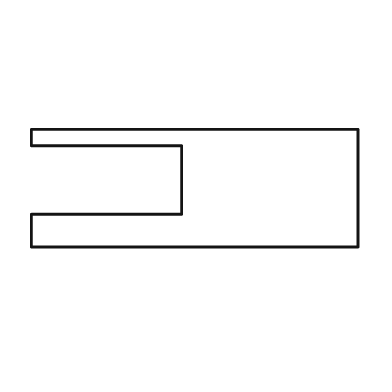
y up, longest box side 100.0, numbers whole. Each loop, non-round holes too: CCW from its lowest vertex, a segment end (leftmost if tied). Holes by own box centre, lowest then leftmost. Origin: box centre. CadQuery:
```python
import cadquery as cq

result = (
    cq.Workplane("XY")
    .moveTo(-50.0, -18.0)
    .lineTo(50.0, -18.0)
    .lineTo(50.0, 18.0)
    .lineTo(-50.0, 18.0)
    .lineTo(-50.0, 13.0)
    .lineTo(-4.0, 13.0)
    .lineTo(-4.0, -8.0)
    .lineTo(-50.0, -8.0)
    .close()
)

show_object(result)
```